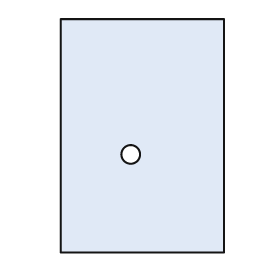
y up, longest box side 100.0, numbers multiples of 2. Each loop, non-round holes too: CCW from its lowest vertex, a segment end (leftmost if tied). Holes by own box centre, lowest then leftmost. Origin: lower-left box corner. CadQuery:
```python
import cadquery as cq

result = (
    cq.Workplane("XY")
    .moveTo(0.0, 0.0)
    .lineTo(70.0, 0.0)
    .lineTo(70.0, 100.0)
    .lineTo(0.0, 100.0)
    .close()
    .moveTo(30.0, 42.0)
    .circle(4.0)
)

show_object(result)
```